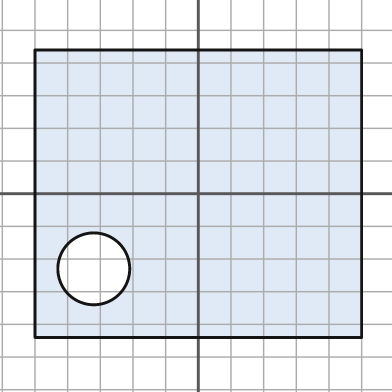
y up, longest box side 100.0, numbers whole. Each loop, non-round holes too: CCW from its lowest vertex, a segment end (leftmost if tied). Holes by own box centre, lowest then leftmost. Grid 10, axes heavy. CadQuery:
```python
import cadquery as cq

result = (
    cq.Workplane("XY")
    .moveTo(-50.0, -44.0)
    .lineTo(50.0, -44.0)
    .lineTo(50.0, 44.0)
    .lineTo(-50.0, 44.0)
    .close()
    .moveTo(-32.0, -23.0)
    .circle(11.0)
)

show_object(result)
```